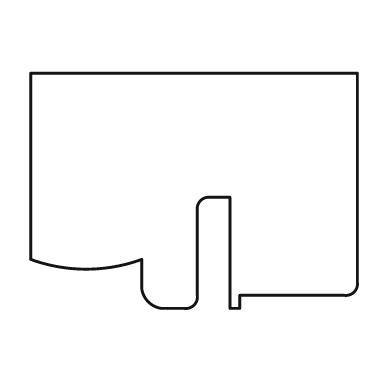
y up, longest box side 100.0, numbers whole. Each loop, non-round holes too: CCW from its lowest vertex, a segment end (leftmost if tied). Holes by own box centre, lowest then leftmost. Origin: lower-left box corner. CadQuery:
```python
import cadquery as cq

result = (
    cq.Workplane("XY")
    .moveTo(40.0, 0.0)
    .lineTo(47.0, 0.0)
    .threePointArc((50.0, 1.0), (51.0, 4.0))
    .lineTo(51.0, 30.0)
    .threePointArc((52.0, 33.0), (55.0, 34.0))
    .lineTo(61.0, 34.0)
    .lineTo(61.0, 0.0)
    .lineTo(64.0, 0.0)
    .lineTo(64.0, 4.0)
    .lineTo(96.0, 4.0)
    .threePointArc((99.0, 5.0), (100.0, 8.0))
    .lineTo(100.0, 72.0)
    .lineTo(0.0, 72.0)
    .lineTo(0.0, 15.0)
    .threePointArc((17.0, 12.0), (34.0, 15.0))
    .lineTo(34.0, 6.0)
    .threePointArc((36.0, 2.0), (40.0, 0.0))
    .close()
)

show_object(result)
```